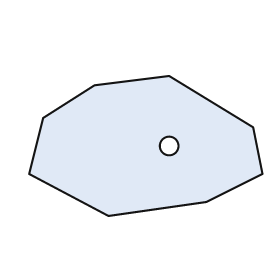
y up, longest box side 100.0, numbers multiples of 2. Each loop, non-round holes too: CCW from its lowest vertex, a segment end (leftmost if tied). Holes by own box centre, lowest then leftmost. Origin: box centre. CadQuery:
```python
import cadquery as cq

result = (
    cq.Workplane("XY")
    .moveTo(-16.0, -30.0)
    .lineTo(26.0, -24.0)
    .lineTo(50.0, -12.0)
    .lineTo(46.0, 8.0)
    .lineTo(10.0, 30.0)
    .lineTo(-22.0, 26.0)
    .lineTo(-44.0, 12.0)
    .lineTo(-50.0, -12.0)
    .close()
    .moveTo(10.0, 0.0)
    .circle(4.0)
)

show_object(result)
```